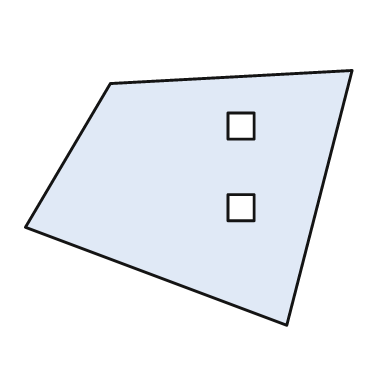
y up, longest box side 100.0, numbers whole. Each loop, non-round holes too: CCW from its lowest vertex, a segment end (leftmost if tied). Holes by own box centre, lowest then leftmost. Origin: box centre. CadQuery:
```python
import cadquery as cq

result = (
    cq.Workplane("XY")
    .moveTo(30.0, -39.0)
    .lineTo(50.0, 39.0)
    .lineTo(-24.0, 35.0)
    .lineTo(-50.0, -9.0)
    .close()
    .moveTo(12.0, -7.0)
    .lineTo(20.0, -7.0)
    .lineTo(20.0, 1.0)
    .lineTo(12.0, 1.0)
    .close()
    .moveTo(12.0, 18.0)
    .lineTo(20.0, 18.0)
    .lineTo(20.0, 26.0)
    .lineTo(12.0, 26.0)
    .close()
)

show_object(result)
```